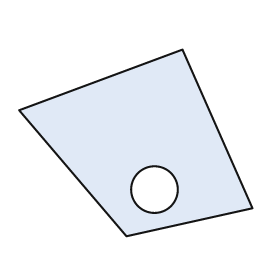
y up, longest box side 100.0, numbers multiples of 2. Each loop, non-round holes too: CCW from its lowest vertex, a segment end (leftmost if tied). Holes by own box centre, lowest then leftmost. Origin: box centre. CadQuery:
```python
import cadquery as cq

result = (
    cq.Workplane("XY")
    .moveTo(-4.0, -40.0)
    .lineTo(50.0, -28.0)
    .lineTo(20.0, 40.0)
    .lineTo(-50.0, 14.0)
    .close()
    .moveTo(8.0, -20.0)
    .circle(10.0)
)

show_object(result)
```